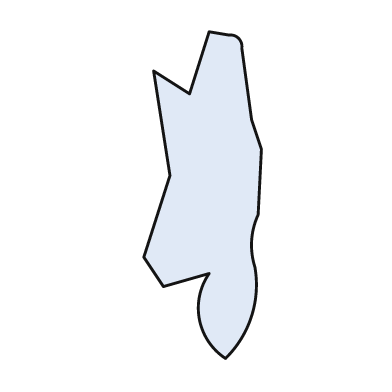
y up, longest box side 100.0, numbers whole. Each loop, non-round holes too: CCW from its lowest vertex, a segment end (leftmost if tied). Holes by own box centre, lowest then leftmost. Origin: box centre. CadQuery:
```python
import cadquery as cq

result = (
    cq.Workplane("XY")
    .moveTo(7.0, -50.0)
    .threePointArc((15.0, -37.0), (16.0, -22.0))
    .threePointArc((15.0, -14.0), (17.0, -6.0))
    .lineTo(18.0, 14.0)
    .lineTo(15.0, 23.0)
    .lineTo(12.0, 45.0)
    .threePointArc((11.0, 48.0), (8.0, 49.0))
    .lineTo(2.0, 50.0)
    .lineTo(-4.0, 31.0)
    .lineTo(-15.0, 38.0)
    .lineTo(-10.0, 6.0)
    .lineTo(-18.0, -19.0)
    .lineTo(-12.0, -28.0)
    .lineTo(2.0, -24.0)
    .threePointArc((-1.0, -38.0), (7.0, -50.0))
    .close()
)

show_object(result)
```